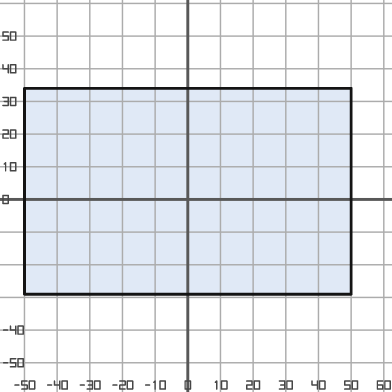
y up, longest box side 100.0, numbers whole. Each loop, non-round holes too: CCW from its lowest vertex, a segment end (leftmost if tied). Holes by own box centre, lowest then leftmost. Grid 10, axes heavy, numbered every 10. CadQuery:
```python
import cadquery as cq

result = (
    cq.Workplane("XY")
    .moveTo(-50.0, -29.0)
    .lineTo(50.0, -29.0)
    .lineTo(50.0, 34.0)
    .lineTo(-50.0, 34.0)
    .close()
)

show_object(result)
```